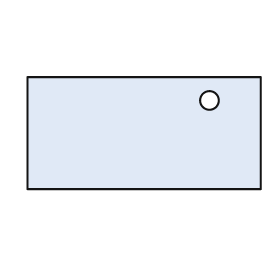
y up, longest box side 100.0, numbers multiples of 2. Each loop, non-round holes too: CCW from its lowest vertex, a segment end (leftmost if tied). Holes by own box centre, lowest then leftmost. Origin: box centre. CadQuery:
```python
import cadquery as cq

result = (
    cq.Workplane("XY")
    .moveTo(-50.0, -24.0)
    .lineTo(50.0, -24.0)
    .lineTo(50.0, 24.0)
    .lineTo(-50.0, 24.0)
    .close()
    .moveTo(28.0, 14.0)
    .circle(4.0)
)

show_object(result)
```